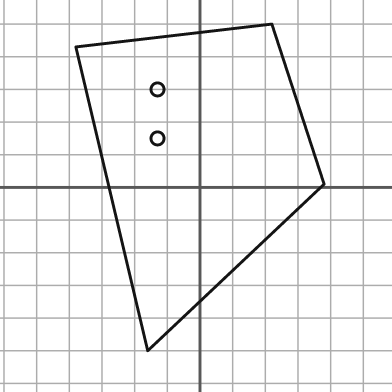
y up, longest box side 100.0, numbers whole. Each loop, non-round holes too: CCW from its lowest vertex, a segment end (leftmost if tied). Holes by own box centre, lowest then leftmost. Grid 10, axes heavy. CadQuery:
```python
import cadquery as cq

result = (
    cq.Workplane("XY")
    .moveTo(-16.0, -50.0)
    .lineTo(38.0, 1.0)
    .lineTo(22.0, 50.0)
    .lineTo(-38.0, 43.0)
    .close()
    .moveTo(-13.0, 15.0)
    .circle(2.0)
    .moveTo(-13.0, 30.0)
    .circle(2.0)
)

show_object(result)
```